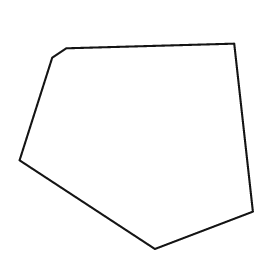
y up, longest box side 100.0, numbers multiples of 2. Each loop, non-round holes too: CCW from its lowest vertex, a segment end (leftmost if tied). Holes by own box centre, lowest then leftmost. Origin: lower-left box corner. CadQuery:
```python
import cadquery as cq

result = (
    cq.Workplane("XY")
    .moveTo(58.0, 0.0)
    .lineTo(100.0, 16.0)
    .lineTo(92.0, 88.0)
    .lineTo(20.0, 86.0)
    .lineTo(14.0, 82.0)
    .lineTo(0.0, 38.0)
    .close()
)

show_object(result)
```